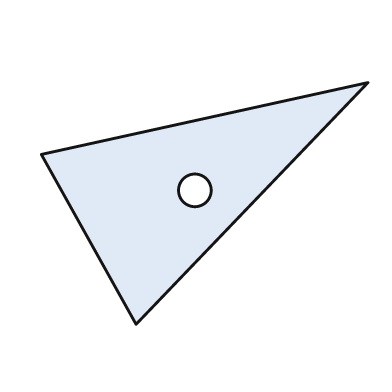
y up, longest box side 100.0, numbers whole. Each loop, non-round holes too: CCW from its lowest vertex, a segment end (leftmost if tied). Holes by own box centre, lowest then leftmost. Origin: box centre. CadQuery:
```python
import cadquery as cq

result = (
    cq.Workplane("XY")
    .moveTo(-21.0, -37.0)
    .lineTo(50.0, 37.0)
    .lineTo(-50.0, 15.0)
    .close()
    .moveTo(-3.0, 4.0)
    .circle(5.0)
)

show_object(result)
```